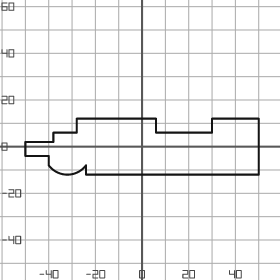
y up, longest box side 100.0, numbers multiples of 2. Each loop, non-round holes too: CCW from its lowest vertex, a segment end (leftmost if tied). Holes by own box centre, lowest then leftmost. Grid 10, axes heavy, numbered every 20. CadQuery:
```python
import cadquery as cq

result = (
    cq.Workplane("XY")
    .moveTo(-24.0, -12.0)
    .lineTo(50.0, -12.0)
    .lineTo(50.0, 12.0)
    .lineTo(30.0, 12.0)
    .lineTo(30.0, 6.0)
    .lineTo(6.0, 6.0)
    .lineTo(6.0, 12.0)
    .lineTo(-28.0, 12.0)
    .lineTo(-28.0, 6.0)
    .lineTo(-38.0, 6.0)
    .lineTo(-38.0, 2.0)
    .lineTo(-50.0, 2.0)
    .lineTo(-50.0, -4.0)
    .lineTo(-40.0, -4.0)
    .lineTo(-40.0, -8.0)
    .threePointArc((-32.0, -12.0), (-24.0, -8.0))
    .close()
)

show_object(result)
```